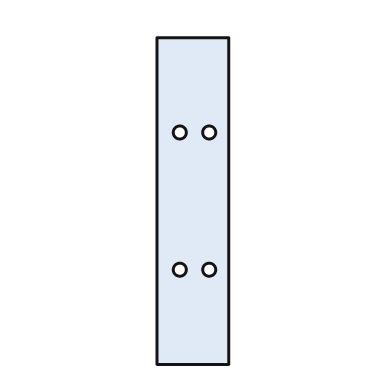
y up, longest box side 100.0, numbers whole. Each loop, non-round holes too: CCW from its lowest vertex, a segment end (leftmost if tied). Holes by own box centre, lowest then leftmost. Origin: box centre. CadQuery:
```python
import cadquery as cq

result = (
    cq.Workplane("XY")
    .moveTo(-11.0, -50.0)
    .lineTo(11.0, -50.0)
    .lineTo(11.0, 50.0)
    .lineTo(-11.0, 50.0)
    .close()
    .moveTo(-4.0, -21.0)
    .circle(2.0)
    .moveTo(5.0, -21.0)
    .circle(2.0)
    .moveTo(-4.0, 21.0)
    .circle(2.0)
    .moveTo(5.0, 21.0)
    .circle(2.0)
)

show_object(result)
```